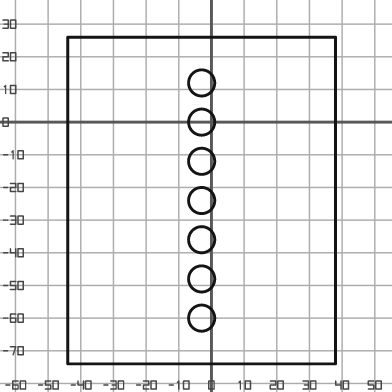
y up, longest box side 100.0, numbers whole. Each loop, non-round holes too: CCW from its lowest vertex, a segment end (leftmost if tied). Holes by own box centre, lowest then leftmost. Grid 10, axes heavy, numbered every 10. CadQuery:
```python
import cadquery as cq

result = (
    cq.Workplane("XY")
    .moveTo(-44.0, -74.0)
    .lineTo(38.0, -74.0)
    .lineTo(38.0, 26.0)
    .lineTo(-44.0, 26.0)
    .close()
    .moveTo(-3.0, -60.0)
    .circle(4.0)
    .moveTo(-3.0, -48.0)
    .circle(4.0)
    .moveTo(-3.0, -36.0)
    .circle(4.0)
    .moveTo(-3.0, -24.0)
    .circle(4.0)
    .moveTo(-3.0, -12.0)
    .circle(4.0)
    .moveTo(-3.0, 0.0)
    .circle(4.0)
    .moveTo(-3.0, 12.0)
    .circle(4.0)
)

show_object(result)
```